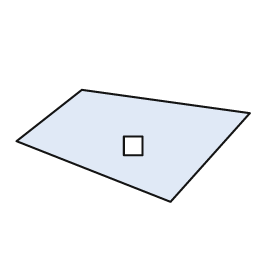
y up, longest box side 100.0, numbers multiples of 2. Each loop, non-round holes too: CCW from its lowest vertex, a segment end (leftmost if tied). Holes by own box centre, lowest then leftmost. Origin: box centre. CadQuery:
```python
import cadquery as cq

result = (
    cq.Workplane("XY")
    .moveTo(16.0, -24.0)
    .lineTo(50.0, 14.0)
    .lineTo(-22.0, 24.0)
    .lineTo(-50.0, 2.0)
    .close()
    .moveTo(-4.0, -4.0)
    .lineTo(4.0, -4.0)
    .lineTo(4.0, 4.0)
    .lineTo(-4.0, 4.0)
    .close()
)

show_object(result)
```